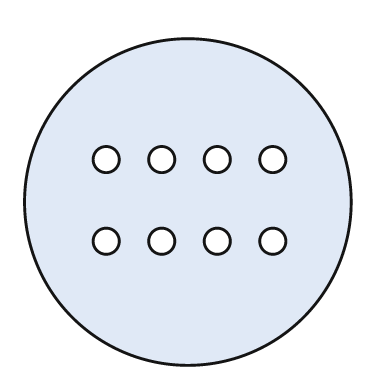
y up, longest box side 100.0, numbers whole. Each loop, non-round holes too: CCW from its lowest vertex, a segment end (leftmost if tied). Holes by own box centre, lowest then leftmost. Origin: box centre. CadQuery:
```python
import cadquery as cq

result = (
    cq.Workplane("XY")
    .moveTo(0.0, 0.0)
    .circle(50.0)
    .moveTo(-25.0, -12.0)
    .circle(4.0)
    .moveTo(-8.0, -12.0)
    .circle(4.0)
    .moveTo(9.0, -12.0)
    .circle(4.0)
    .moveTo(26.0, -12.0)
    .circle(4.0)
    .moveTo(-25.0, 13.0)
    .circle(4.0)
    .moveTo(-8.0, 13.0)
    .circle(4.0)
    .moveTo(9.0, 13.0)
    .circle(4.0)
    .moveTo(26.0, 13.0)
    .circle(4.0)
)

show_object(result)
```